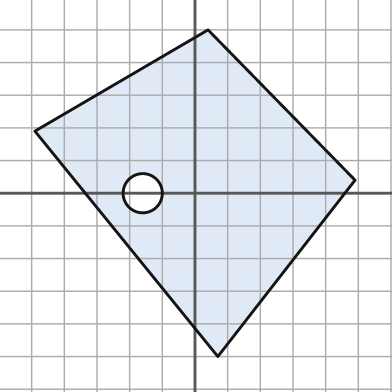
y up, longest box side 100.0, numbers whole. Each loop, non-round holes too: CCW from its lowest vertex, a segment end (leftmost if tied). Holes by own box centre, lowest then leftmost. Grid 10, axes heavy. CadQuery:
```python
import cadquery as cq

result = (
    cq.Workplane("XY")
    .moveTo(7.0, -50.0)
    .lineTo(49.0, 4.0)
    .lineTo(4.0, 50.0)
    .lineTo(-49.0, 19.0)
    .close()
    .moveTo(-16.0, 0.0)
    .circle(6.0)
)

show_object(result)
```